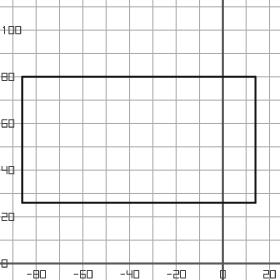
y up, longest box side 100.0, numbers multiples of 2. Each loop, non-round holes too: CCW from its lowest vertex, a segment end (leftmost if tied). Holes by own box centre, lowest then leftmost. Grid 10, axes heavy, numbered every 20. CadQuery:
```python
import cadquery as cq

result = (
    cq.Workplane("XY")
    .moveTo(-86.0, 26.0)
    .lineTo(14.0, 26.0)
    .lineTo(14.0, 80.0)
    .lineTo(-86.0, 80.0)
    .close()
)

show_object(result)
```